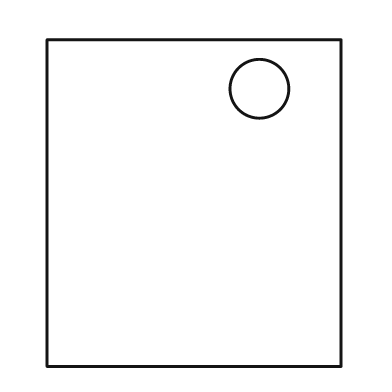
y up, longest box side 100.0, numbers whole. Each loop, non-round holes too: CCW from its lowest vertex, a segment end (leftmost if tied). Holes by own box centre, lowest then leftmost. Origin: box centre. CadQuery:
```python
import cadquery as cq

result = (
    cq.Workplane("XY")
    .moveTo(-45.0, -50.0)
    .lineTo(45.0, -50.0)
    .lineTo(45.0, 50.0)
    .lineTo(-45.0, 50.0)
    .close()
    .moveTo(20.0, 35.0)
    .circle(9.0)
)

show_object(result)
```